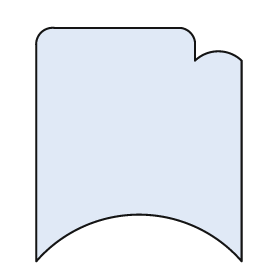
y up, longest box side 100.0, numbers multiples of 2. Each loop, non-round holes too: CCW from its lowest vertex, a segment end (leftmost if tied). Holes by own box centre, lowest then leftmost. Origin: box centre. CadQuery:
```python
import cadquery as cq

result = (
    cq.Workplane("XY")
    .moveTo(-44.0, -50.0)
    .threePointArc((0.0, -30.0), (44.0, -50.0))
    .lineTo(44.0, 36.0)
    .threePointArc((34.0, 40.0), (24.0, 36.0))
    .lineTo(24.0, 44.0)
    .threePointArc((22.0, 48.0), (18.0, 50.0))
    .lineTo(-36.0, 50.0)
    .threePointArc((-42.0, 48.0), (-44.0, 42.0))
    .close()
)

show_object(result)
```